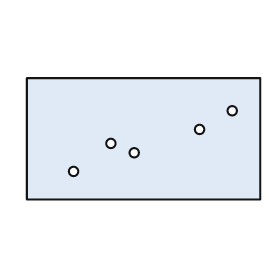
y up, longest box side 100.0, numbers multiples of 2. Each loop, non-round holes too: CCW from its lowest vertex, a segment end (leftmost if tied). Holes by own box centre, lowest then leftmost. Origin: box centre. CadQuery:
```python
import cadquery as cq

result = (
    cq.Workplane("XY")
    .moveTo(-50.0, -26.0)
    .lineTo(50.0, -26.0)
    .lineTo(50.0, 26.0)
    .lineTo(-50.0, 26.0)
    .close()
    .moveTo(-30.0, -14.0)
    .circle(2.0)
    .moveTo(-4.0, -6.0)
    .circle(2.0)
    .moveTo(-14.0, -2.0)
    .circle(2.0)
    .moveTo(24.0, 4.0)
    .circle(2.0)
    .moveTo(38.0, 12.0)
    .circle(2.0)
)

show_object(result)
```